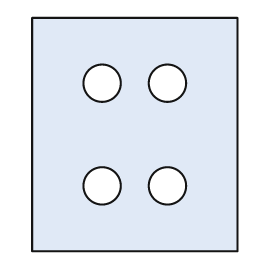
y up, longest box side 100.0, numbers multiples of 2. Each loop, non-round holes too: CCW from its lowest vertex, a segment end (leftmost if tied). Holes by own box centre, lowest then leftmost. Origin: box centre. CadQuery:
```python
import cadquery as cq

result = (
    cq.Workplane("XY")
    .moveTo(-44.0, -50.0)
    .lineTo(44.0, -50.0)
    .lineTo(44.0, 50.0)
    .lineTo(-44.0, 50.0)
    .close()
    .moveTo(-14.0, -22.0)
    .circle(8.0)
    .moveTo(14.0, -22.0)
    .circle(8.0)
    .moveTo(-14.0, 22.0)
    .circle(8.0)
    .moveTo(14.0, 22.0)
    .circle(8.0)
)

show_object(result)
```